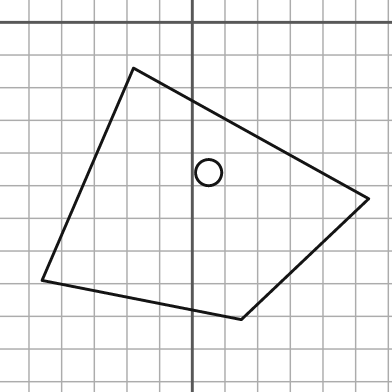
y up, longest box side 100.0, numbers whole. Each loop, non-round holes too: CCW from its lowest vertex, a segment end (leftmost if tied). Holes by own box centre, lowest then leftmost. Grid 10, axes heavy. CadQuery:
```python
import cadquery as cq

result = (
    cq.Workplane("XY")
    .moveTo(15.0, -91.0)
    .lineTo(54.0, -54.0)
    .lineTo(-18.0, -14.0)
    .lineTo(-46.0, -79.0)
    .close()
    .moveTo(5.0, -46.0)
    .circle(4.0)
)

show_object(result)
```